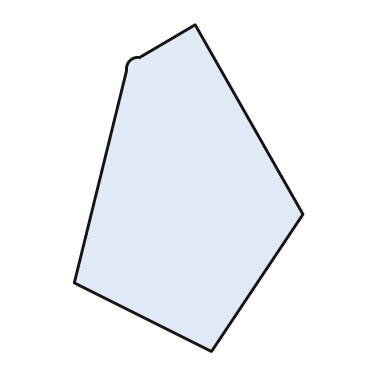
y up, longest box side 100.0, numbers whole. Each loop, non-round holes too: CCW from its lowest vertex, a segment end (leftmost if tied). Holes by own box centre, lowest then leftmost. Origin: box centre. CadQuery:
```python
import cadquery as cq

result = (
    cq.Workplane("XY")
    .moveTo(7.0, -50.0)
    .lineTo(35.0, -8.0)
    .lineTo(2.0, 50.0)
    .lineTo(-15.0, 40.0)
    .threePointArc((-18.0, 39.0), (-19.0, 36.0))
    .lineTo(-35.0, -29.0)
    .close()
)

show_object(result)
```